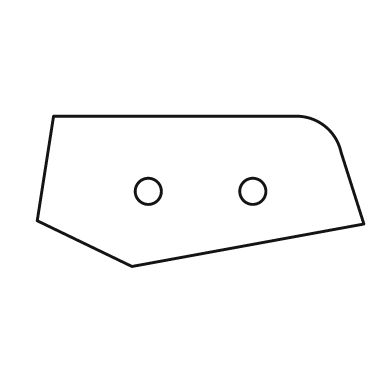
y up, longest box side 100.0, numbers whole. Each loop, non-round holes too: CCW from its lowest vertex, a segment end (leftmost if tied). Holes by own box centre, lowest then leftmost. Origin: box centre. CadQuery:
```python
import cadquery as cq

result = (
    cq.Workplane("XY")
    .moveTo(-21.0, -23.0)
    .lineTo(50.0, -10.0)
    .lineTo(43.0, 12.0)
    .threePointArc((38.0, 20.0), (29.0, 23.0))
    .lineTo(-45.0, 23.0)
    .lineTo(-50.0, -9.0)
    .close()
    .moveTo(-16.0, 0.0)
    .circle(4.0)
    .moveTo(16.0, 0.0)
    .circle(4.0)
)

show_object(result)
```